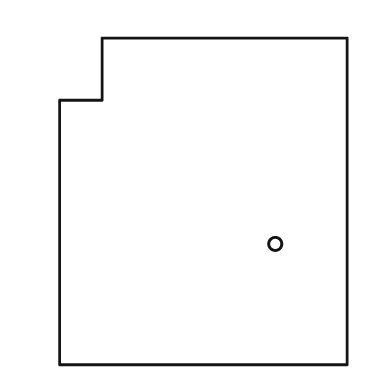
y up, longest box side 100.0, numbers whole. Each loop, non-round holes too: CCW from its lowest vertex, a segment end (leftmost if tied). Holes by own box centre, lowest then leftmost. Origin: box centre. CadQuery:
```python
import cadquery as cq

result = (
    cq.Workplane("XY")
    .moveTo(-44.0, -50.0)
    .lineTo(44.0, -50.0)
    .lineTo(44.0, 50.0)
    .lineTo(-31.0, 50.0)
    .lineTo(-31.0, 31.0)
    .lineTo(-44.0, 31.0)
    .close()
    .moveTo(22.0, -13.0)
    .circle(2.0)
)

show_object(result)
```